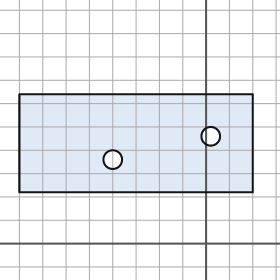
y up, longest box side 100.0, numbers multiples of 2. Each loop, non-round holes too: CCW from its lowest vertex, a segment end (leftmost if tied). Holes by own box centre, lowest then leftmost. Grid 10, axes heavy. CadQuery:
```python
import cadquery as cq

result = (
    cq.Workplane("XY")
    .moveTo(-80.0, 22.0)
    .lineTo(20.0, 22.0)
    .lineTo(20.0, 64.0)
    .lineTo(-80.0, 64.0)
    .close()
    .moveTo(-40.0, 36.0)
    .circle(4.0)
    .moveTo(2.0, 46.0)
    .circle(4.0)
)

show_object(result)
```